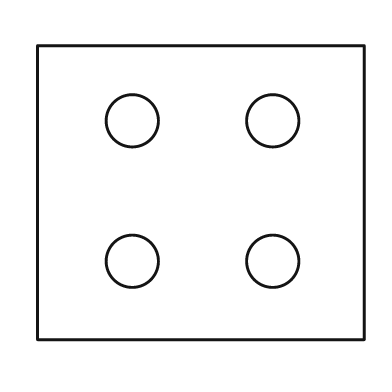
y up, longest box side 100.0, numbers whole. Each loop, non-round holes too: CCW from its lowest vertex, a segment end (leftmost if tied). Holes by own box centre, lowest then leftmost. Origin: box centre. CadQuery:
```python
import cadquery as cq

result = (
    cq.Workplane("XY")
    .moveTo(-50.0, -45.0)
    .lineTo(50.0, -45.0)
    .lineTo(50.0, 45.0)
    .lineTo(-50.0, 45.0)
    .close()
    .moveTo(-21.0, -21.0)
    .circle(8.0)
    .moveTo(22.0, -21.0)
    .circle(8.0)
    .moveTo(-21.0, 22.0)
    .circle(8.0)
    .moveTo(22.0, 22.0)
    .circle(8.0)
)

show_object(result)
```